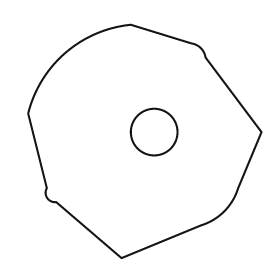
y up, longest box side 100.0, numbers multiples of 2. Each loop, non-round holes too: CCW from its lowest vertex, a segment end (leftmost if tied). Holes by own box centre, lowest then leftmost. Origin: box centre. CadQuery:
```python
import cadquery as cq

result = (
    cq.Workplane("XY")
    .moveTo(-10.0, -50.0)
    .lineTo(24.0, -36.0)
    .threePointArc((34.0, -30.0), (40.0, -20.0))
    .lineTo(50.0, 4.0)
    .lineTo(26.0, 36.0)
    .threePointArc((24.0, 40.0), (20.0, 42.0))
    .lineTo(-6.0, 50.0)
    .threePointArc((-34.0, 38.0), (-50.0, 12.0))
    .lineTo(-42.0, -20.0)
    .threePointArc((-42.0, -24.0), (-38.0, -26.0))
    .close()
    .moveTo(4.0, 4.0)
    .circle(10.0)
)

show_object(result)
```